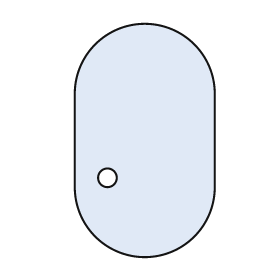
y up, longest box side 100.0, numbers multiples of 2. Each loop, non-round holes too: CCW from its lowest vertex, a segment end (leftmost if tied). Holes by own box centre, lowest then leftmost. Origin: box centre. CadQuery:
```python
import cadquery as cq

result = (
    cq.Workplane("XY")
    .moveTo(-30.0, -20.0)
    .threePointArc((0.0, -50.0), (30.0, -20.0))
    .lineTo(30.0, 20.0)
    .threePointArc((0.0, 50.0), (-30.0, 20.0))
    .close()
    .moveTo(-16.0, -16.0)
    .circle(4.0)
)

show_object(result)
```